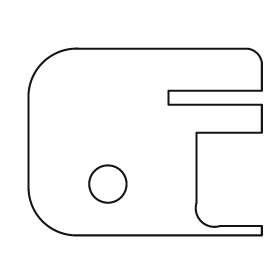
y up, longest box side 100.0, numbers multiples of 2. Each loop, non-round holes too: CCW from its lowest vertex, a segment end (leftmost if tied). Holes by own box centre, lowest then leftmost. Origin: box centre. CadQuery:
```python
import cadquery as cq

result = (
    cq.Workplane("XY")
    .moveTo(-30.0, -40.0)
    .lineTo(50.0, -40.0)
    .lineTo(50.0, -36.0)
    .lineTo(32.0, -36.0)
    .threePointArc((24.0, -34.0), (22.0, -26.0))
    .lineTo(22.0, 4.0)
    .lineTo(50.0, 4.0)
    .lineTo(50.0, 16.0)
    .lineTo(10.0, 16.0)
    .lineTo(10.0, 22.0)
    .lineTo(50.0, 22.0)
    .lineTo(50.0, 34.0)
    .threePointArc((48.0, 38.0), (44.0, 40.0))
    .lineTo(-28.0, 40.0)
    .threePointArc((-44.0, 34.0), (-50.0, 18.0))
    .lineTo(-50.0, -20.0)
    .threePointArc((-44.0, -34.0), (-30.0, -40.0))
    .close()
    .moveTo(-16.0, -18.0)
    .circle(8.0)
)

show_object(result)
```